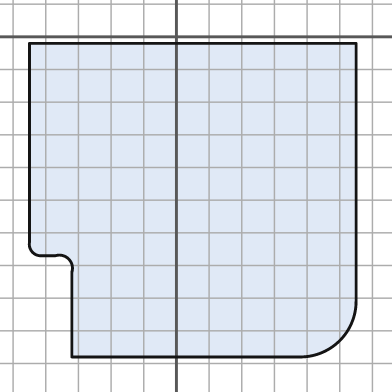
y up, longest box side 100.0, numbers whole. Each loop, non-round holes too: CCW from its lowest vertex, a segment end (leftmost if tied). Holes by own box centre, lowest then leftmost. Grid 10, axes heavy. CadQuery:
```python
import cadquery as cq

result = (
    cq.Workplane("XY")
    .moveTo(-32.0, -98.0)
    .lineTo(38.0, -98.0)
    .threePointArc((50.0, -93.0), (55.0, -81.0))
    .lineTo(55.0, -2.0)
    .lineTo(-45.0, -2.0)
    .lineTo(-45.0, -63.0)
    .threePointArc((-44.0, -66.0), (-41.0, -67.0))
    .lineTo(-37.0, -67.0)
    .threePointArc((-33.0, -68.0), (-32.0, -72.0))
    .close()
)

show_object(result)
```